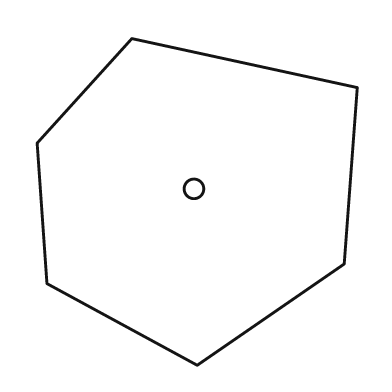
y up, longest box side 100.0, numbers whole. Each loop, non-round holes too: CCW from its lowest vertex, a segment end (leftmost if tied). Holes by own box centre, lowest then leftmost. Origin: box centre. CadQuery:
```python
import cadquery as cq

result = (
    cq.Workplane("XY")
    .moveTo(0.0, -50.0)
    .lineTo(45.0, -19.0)
    .lineTo(49.0, 35.0)
    .lineTo(-20.0, 50.0)
    .lineTo(-49.0, 18.0)
    .lineTo(-46.0, -25.0)
    .close()
    .moveTo(-1.0, 4.0)
    .circle(3.0)
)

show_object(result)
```